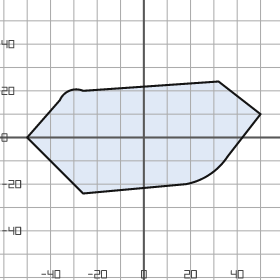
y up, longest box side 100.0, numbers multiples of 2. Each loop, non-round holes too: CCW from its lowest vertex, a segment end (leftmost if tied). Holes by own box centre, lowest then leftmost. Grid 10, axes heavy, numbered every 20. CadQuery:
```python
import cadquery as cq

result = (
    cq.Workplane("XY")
    .moveTo(-26.0, -24.0)
    .lineTo(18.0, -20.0)
    .threePointArc((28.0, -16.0), (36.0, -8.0))
    .lineTo(50.0, 10.0)
    .lineTo(32.0, 24.0)
    .lineTo(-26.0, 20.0)
    .threePointArc((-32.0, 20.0), (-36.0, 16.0))
    .lineTo(-50.0, 0.0)
    .close()
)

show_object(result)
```